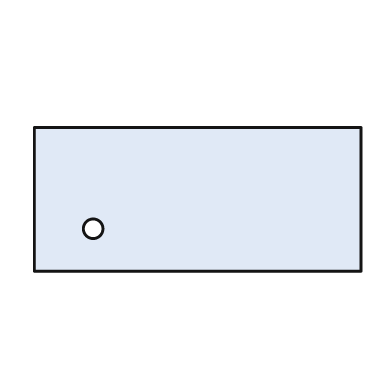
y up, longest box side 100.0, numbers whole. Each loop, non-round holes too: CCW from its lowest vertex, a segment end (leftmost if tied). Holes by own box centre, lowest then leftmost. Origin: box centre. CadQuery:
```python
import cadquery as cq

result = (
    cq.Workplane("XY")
    .moveTo(-50.0, -22.0)
    .lineTo(50.0, -22.0)
    .lineTo(50.0, 22.0)
    .lineTo(-50.0, 22.0)
    .close()
    .moveTo(-32.0, -9.0)
    .circle(3.0)
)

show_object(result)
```